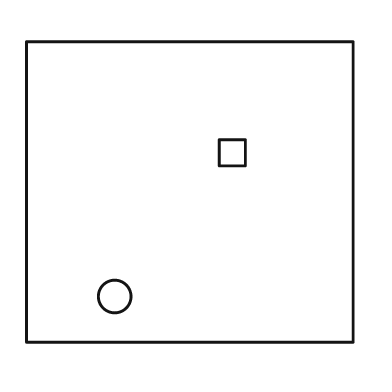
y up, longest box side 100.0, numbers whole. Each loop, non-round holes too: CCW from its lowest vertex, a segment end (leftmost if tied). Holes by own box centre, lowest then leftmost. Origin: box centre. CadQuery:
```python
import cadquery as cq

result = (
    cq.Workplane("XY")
    .moveTo(-50.0, -46.0)
    .lineTo(50.0, -46.0)
    .lineTo(50.0, 46.0)
    .lineTo(-50.0, 46.0)
    .close()
    .moveTo(-23.0, -32.0)
    .circle(5.0)
    .moveTo(9.0, 8.0)
    .lineTo(17.0, 8.0)
    .lineTo(17.0, 16.0)
    .lineTo(9.0, 16.0)
    .close()
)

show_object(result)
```